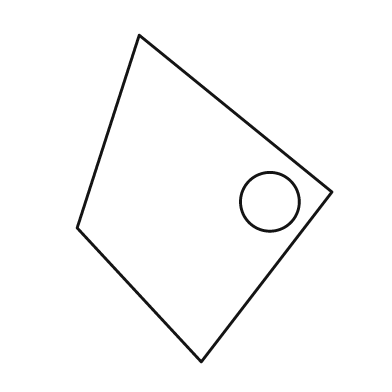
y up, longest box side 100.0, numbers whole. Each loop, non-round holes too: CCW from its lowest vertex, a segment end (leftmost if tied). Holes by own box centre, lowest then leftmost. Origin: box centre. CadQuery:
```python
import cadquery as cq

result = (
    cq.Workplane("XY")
    .moveTo(-1.0, -50.0)
    .lineTo(39.0, 2.0)
    .lineTo(-20.0, 50.0)
    .lineTo(-39.0, -9.0)
    .close()
    .moveTo(20.0, -1.0)
    .circle(9.0)
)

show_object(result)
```